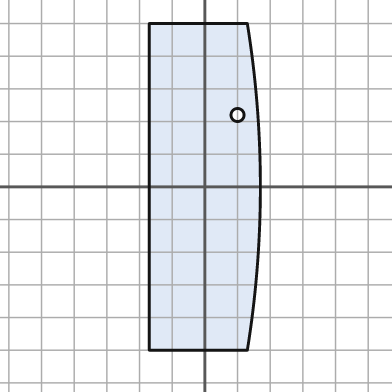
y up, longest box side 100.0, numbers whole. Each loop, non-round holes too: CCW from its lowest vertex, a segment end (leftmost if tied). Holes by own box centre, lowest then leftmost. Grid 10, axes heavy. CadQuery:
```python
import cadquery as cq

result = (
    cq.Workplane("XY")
    .moveTo(-17.0, -50.0)
    .lineTo(13.0, -50.0)
    .threePointArc((17.0, 0.0), (13.0, 50.0))
    .lineTo(-17.0, 50.0)
    .close()
    .moveTo(10.0, 22.0)
    .circle(2.0)
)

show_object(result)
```